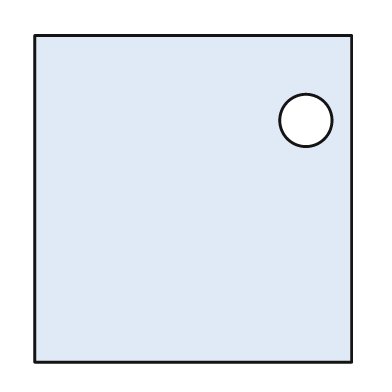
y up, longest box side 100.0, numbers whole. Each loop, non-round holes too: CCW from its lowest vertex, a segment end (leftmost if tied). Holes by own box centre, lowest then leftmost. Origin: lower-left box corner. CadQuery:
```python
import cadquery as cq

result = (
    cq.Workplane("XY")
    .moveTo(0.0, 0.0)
    .lineTo(97.0, 0.0)
    .lineTo(97.0, 100.0)
    .lineTo(0.0, 100.0)
    .close()
    .moveTo(83.0, 74.0)
    .circle(8.0)
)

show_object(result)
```